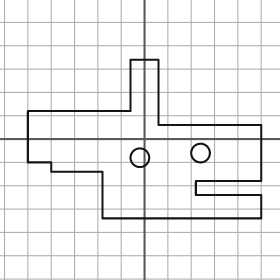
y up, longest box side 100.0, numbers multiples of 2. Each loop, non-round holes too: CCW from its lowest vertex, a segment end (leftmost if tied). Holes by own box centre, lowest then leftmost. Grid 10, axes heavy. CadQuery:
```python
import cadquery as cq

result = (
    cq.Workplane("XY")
    .moveTo(-18.0, -34.0)
    .lineTo(50.0, -34.0)
    .lineTo(50.0, -24.0)
    .lineTo(22.0, -24.0)
    .lineTo(22.0, -18.0)
    .lineTo(50.0, -18.0)
    .lineTo(50.0, 6.0)
    .lineTo(6.0, 6.0)
    .lineTo(6.0, 34.0)
    .lineTo(-6.0, 34.0)
    .lineTo(-6.0, 12.0)
    .lineTo(-50.0, 12.0)
    .lineTo(-50.0, -10.0)
    .lineTo(-40.0, -10.0)
    .lineTo(-40.0, -14.0)
    .lineTo(-18.0, -14.0)
    .close()
    .moveTo(-2.0, -8.0)
    .circle(4.0)
    .moveTo(24.0, -6.0)
    .circle(4.0)
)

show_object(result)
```